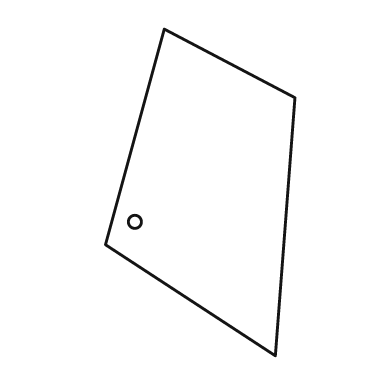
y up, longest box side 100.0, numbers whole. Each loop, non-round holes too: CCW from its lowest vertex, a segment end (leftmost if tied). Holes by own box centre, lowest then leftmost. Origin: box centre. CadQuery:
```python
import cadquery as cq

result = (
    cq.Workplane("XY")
    .moveTo(23.0, -50.0)
    .lineTo(29.0, 29.0)
    .lineTo(-11.0, 50.0)
    .lineTo(-29.0, -16.0)
    .close()
    .moveTo(-20.0, -9.0)
    .circle(2.0)
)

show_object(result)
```